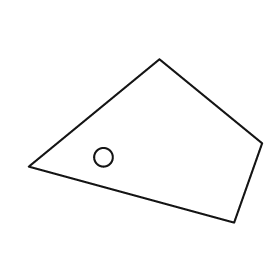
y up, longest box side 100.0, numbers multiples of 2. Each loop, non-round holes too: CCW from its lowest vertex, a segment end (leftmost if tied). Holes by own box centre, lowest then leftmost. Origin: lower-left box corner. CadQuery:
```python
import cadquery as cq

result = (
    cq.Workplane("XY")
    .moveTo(88.0, 0.0)
    .lineTo(100.0, 34.0)
    .lineTo(56.0, 70.0)
    .lineTo(0.0, 24.0)
    .close()
    .moveTo(32.0, 28.0)
    .circle(4.0)
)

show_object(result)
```